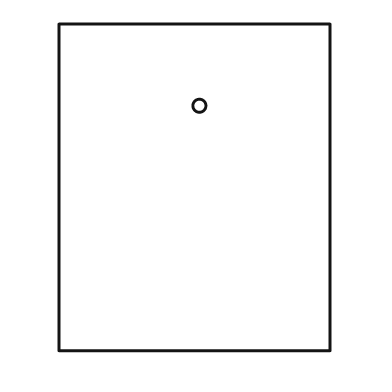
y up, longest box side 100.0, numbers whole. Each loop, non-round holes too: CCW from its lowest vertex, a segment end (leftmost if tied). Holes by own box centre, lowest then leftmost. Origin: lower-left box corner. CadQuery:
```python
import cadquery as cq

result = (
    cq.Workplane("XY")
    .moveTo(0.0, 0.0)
    .lineTo(83.0, 0.0)
    .lineTo(83.0, 100.0)
    .lineTo(0.0, 100.0)
    .close()
    .moveTo(43.0, 75.0)
    .circle(2.0)
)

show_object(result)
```